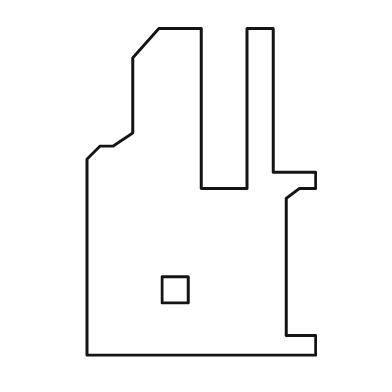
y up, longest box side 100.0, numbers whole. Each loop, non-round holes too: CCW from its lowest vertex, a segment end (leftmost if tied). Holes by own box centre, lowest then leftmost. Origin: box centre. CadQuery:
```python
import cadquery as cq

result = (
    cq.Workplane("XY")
    .moveTo(-35.0, -50.0)
    .lineTo(35.0, -50.0)
    .lineTo(35.0, -44.0)
    .lineTo(26.0, -44.0)
    .lineTo(26.0, -2.0)
    .lineTo(30.0, 1.0)
    .lineTo(35.0, 1.0)
    .lineTo(35.0, 6.0)
    .lineTo(22.0, 6.0)
    .lineTo(22.0, 50.0)
    .lineTo(14.0, 50.0)
    .lineTo(14.0, 1.0)
    .lineTo(0.0, 1.0)
    .lineTo(0.0, 50.0)
    .lineTo(-13.0, 50.0)
    .lineTo(-21.0, 41.0)
    .lineTo(-21.0, 18.0)
    .lineTo(-27.0, 14.0)
    .lineTo(-31.0, 14.0)
    .lineTo(-35.0, 10.0)
    .close()
    .moveTo(-12.0, -34.0)
    .lineTo(-4.0, -34.0)
    .lineTo(-4.0, -26.0)
    .lineTo(-12.0, -26.0)
    .close()
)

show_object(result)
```